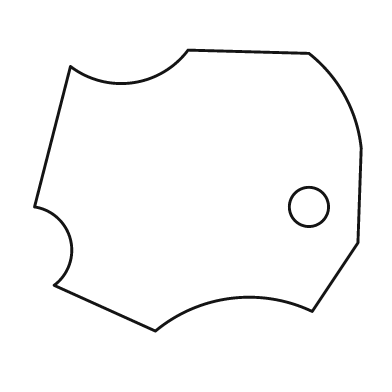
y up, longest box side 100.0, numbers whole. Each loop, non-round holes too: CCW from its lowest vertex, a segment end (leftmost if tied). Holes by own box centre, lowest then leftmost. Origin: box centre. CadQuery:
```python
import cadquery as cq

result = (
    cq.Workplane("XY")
    .moveTo(-13.0, -43.0)
    .threePointArc((10.0, -33.0), (35.0, -37.0))
    .lineTo(49.0, -16.0)
    .lineTo(50.0, 13.0)
    .threePointArc((45.0, 29.0), (34.0, 42.0))
    .lineTo(-3.0, 43.0)
    .threePointArc((-20.0, 33.0), (-39.0, 38.0))
    .lineTo(-50.0, -5.0)
    .threePointArc((-39.0, -15.0), (-44.0, -29.0))
    .close()
    .moveTo(34.0, -5.0)
    .circle(6.0)
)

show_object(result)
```